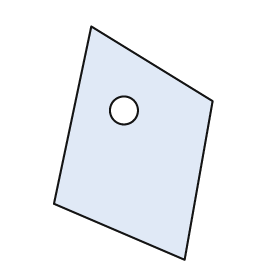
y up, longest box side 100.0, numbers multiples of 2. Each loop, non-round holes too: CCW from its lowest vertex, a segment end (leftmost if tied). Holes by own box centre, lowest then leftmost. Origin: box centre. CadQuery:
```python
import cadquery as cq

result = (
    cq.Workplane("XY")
    .moveTo(22.0, -50.0)
    .lineTo(34.0, 18.0)
    .lineTo(-18.0, 50.0)
    .lineTo(-34.0, -26.0)
    .close()
    .moveTo(-4.0, 14.0)
    .circle(6.0)
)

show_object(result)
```